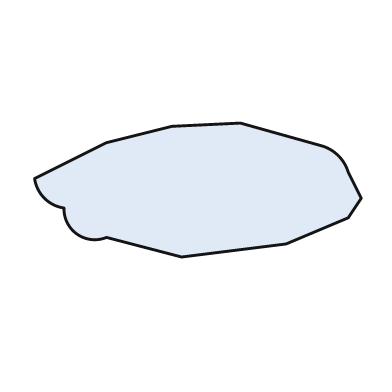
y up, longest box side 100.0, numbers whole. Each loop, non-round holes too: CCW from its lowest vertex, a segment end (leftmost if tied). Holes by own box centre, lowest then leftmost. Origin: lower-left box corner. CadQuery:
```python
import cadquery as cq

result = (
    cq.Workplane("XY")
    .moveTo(45.0, 0.0)
    .lineTo(77.0, 4.0)
    .lineTo(96.0, 12.0)
    .lineTo(100.0, 18.0)
    .lineTo(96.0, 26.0)
    .threePointArc((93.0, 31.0), (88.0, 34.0))
    .lineTo(63.0, 41.0)
    .lineTo(42.0, 40.0)
    .lineTo(22.0, 35.0)
    .lineTo(0.0, 24.0)
    .threePointArc((3.0, 18.0), (9.0, 15.0))
    .threePointArc((13.0, 7.0), (22.0, 6.0))
    .close()
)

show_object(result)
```